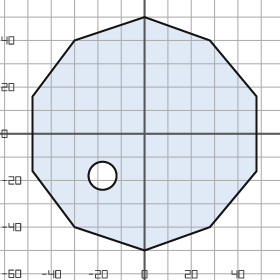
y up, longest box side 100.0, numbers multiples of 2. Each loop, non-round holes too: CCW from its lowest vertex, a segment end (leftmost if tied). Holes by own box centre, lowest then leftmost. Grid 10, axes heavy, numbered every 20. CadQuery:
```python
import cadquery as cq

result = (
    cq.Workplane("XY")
    .moveTo(0.0, -50.0)
    .lineTo(28.0, -40.0)
    .lineTo(48.0, -16.0)
    .lineTo(48.0, 16.0)
    .lineTo(28.0, 40.0)
    .lineTo(0.0, 50.0)
    .lineTo(-30.0, 40.0)
    .lineTo(-48.0, 16.0)
    .lineTo(-48.0, -16.0)
    .lineTo(-30.0, -40.0)
    .close()
    .moveTo(-18.0, -18.0)
    .circle(6.0)
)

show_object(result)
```